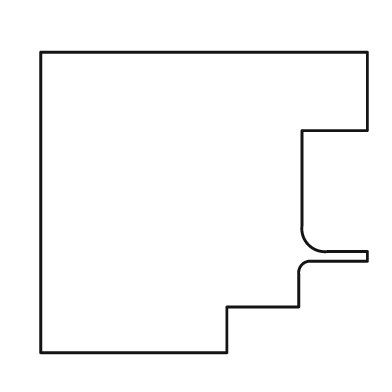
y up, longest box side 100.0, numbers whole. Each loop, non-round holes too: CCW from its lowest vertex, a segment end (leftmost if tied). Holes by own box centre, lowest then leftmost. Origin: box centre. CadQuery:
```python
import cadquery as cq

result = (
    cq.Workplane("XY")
    .moveTo(-50.0, -46.0)
    .lineTo(7.0, -46.0)
    .lineTo(7.0, -32.0)
    .lineTo(29.0, -32.0)
    .lineTo(29.0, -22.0)
    .threePointArc((30.0, -19.0), (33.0, -18.0))
    .lineTo(50.0, -18.0)
    .lineTo(50.0, -15.0)
    .lineTo(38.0, -15.0)
    .threePointArc((32.0, -13.0), (30.0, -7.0))
    .lineTo(30.0, 22.0)
    .lineTo(50.0, 22.0)
    .lineTo(50.0, 46.0)
    .lineTo(-50.0, 46.0)
    .close()
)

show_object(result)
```